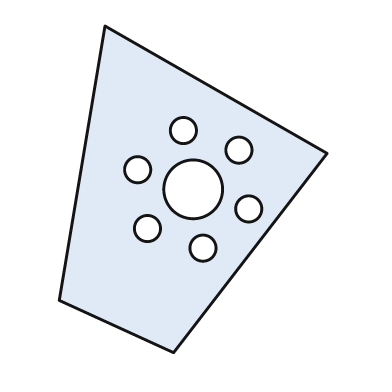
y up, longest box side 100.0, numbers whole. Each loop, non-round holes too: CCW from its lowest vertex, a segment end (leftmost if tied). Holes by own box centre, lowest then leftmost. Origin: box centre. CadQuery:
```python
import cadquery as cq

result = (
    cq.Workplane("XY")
    .moveTo(-6.0, -50.0)
    .lineTo(41.0, 11.0)
    .lineTo(-27.0, 50.0)
    .lineTo(-41.0, -34.0)
    .close()
    .moveTo(3.0, -18.0)
    .circle(4.0)
    .moveTo(-14.0, -12.0)
    .circle(4.0)
    .moveTo(17.0, -6.0)
    .circle(4.0)
    .moveTo(0.0, 0.0)
    .circle(9.0)
    .moveTo(-17.0, 6.0)
    .circle(4.0)
    .moveTo(14.0, 12.0)
    .circle(4.0)
    .moveTo(-3.0, 18.0)
    .circle(4.0)
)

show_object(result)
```